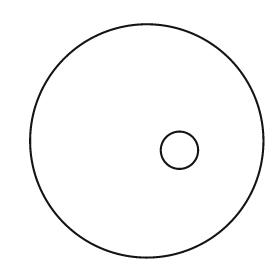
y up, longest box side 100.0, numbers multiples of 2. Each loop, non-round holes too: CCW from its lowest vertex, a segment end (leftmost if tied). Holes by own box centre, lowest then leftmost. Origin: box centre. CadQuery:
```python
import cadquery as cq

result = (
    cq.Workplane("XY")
    .moveTo(0.0, 0.0)
    .circle(50.0)
    .moveTo(14.0, -4.0)
    .circle(8.0)
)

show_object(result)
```